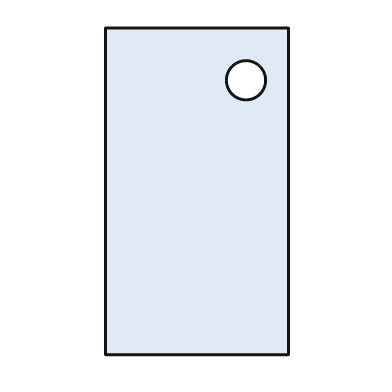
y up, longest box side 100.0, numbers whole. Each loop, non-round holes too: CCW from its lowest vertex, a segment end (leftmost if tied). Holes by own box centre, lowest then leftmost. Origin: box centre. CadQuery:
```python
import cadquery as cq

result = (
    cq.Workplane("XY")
    .moveTo(-28.0, -50.0)
    .lineTo(28.0, -50.0)
    .lineTo(28.0, 50.0)
    .lineTo(-28.0, 50.0)
    .close()
    .moveTo(15.0, 34.0)
    .circle(6.0)
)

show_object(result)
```